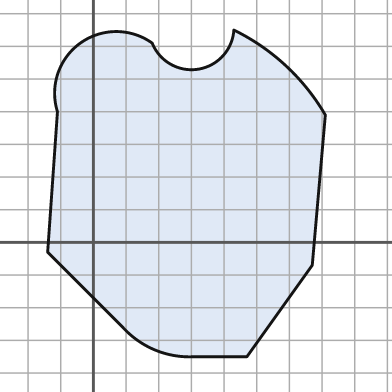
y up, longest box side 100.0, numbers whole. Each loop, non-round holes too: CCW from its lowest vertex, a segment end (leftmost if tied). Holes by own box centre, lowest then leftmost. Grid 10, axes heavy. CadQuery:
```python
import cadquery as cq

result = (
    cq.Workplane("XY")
    .moveTo(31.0, -35.0)
    .lineTo(47.0, -35.0)
    .lineTo(67.0, -7.0)
    .lineTo(71.0, 39.0)
    .threePointArc((59.0, 54.0), (43.0, 65.0))
    .threePointArc((32.0, 53.0), (18.0, 61.0))
    .threePointArc((-4.0, 61.0), (-11.0, 40.0))
    .lineTo(-14.0, -3.0)
    .lineTo(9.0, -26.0)
    .threePointArc((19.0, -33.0), (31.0, -35.0))
    .close()
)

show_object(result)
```